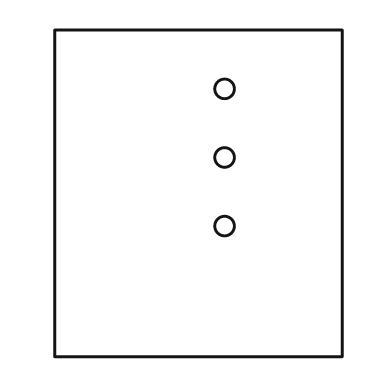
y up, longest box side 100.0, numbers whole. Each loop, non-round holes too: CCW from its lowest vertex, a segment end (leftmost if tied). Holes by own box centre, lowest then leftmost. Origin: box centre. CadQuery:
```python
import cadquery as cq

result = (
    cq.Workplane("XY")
    .moveTo(-44.0, -50.0)
    .lineTo(44.0, -50.0)
    .lineTo(44.0, 50.0)
    .lineTo(-44.0, 50.0)
    .close()
    .moveTo(8.0, -10.0)
    .circle(3.0)
    .moveTo(8.0, 11.0)
    .circle(3.0)
    .moveTo(8.0, 32.0)
    .circle(3.0)
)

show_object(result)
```